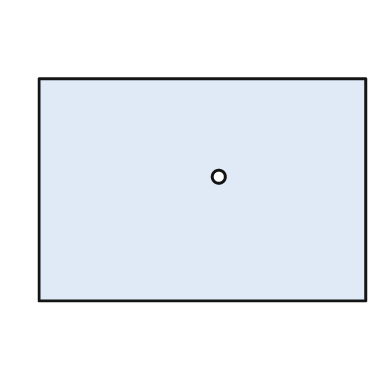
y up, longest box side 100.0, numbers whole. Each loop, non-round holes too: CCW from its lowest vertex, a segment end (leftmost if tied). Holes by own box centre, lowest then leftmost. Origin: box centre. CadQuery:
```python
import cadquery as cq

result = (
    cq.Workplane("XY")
    .moveTo(-50.0, -34.0)
    .lineTo(50.0, -34.0)
    .lineTo(50.0, 34.0)
    .lineTo(-50.0, 34.0)
    .close()
    .moveTo(5.0, 4.0)
    .circle(2.0)
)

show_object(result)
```